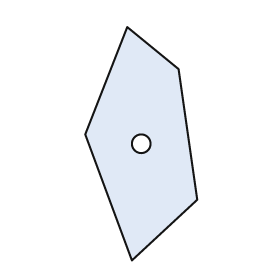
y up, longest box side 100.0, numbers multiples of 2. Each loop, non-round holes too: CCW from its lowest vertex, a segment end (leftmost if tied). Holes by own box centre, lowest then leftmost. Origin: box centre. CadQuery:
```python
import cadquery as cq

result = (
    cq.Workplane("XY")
    .moveTo(-4.0, -50.0)
    .lineTo(24.0, -24.0)
    .lineTo(16.0, 32.0)
    .lineTo(-6.0, 50.0)
    .lineTo(-24.0, 4.0)
    .close()
    .moveTo(0.0, 0.0)
    .circle(4.0)
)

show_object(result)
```